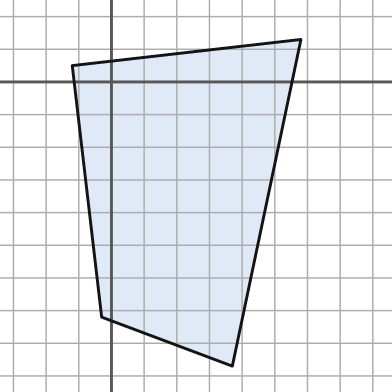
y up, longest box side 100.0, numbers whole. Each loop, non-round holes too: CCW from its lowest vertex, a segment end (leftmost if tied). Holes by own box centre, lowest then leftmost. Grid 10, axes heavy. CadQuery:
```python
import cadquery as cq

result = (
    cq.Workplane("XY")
    .moveTo(37.0, -87.0)
    .lineTo(58.0, 13.0)
    .lineTo(-12.0, 5.0)
    .lineTo(-3.0, -72.0)
    .close()
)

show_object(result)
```